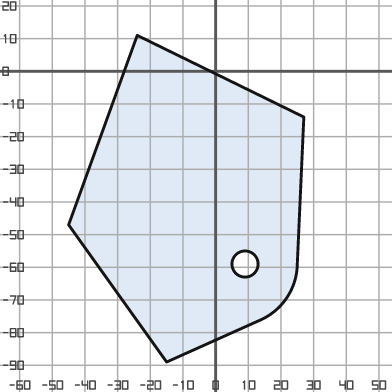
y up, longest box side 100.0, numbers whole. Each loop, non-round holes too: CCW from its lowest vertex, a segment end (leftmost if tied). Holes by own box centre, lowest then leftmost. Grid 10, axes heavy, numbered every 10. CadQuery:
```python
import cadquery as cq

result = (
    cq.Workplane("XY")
    .moveTo(-15.0, -89.0)
    .lineTo(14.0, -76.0)
    .threePointArc((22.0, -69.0), (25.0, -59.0))
    .lineTo(27.0, -14.0)
    .lineTo(-24.0, 11.0)
    .lineTo(-45.0, -47.0)
    .close()
    .moveTo(9.0, -59.0)
    .circle(4.0)
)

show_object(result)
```